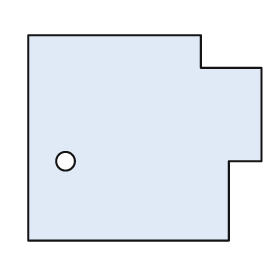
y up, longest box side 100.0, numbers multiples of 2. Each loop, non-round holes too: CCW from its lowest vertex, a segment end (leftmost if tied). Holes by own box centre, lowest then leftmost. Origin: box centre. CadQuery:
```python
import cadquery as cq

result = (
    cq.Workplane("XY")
    .moveTo(-50.0, -44.0)
    .lineTo(36.0, -44.0)
    .lineTo(36.0, -10.0)
    .lineTo(50.0, -10.0)
    .lineTo(50.0, 30.0)
    .lineTo(24.0, 30.0)
    .lineTo(24.0, 44.0)
    .lineTo(-50.0, 44.0)
    .close()
    .moveTo(-34.0, -10.0)
    .circle(4.0)
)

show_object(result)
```